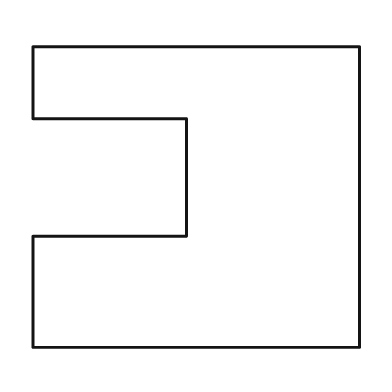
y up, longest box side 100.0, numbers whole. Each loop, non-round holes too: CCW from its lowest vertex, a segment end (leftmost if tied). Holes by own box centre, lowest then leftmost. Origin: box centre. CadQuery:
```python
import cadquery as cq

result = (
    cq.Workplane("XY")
    .moveTo(-50.0, -46.0)
    .lineTo(50.0, -46.0)
    .lineTo(50.0, 46.0)
    .lineTo(-50.0, 46.0)
    .lineTo(-50.0, 24.0)
    .lineTo(-3.0, 24.0)
    .lineTo(-3.0, -12.0)
    .lineTo(-50.0, -12.0)
    .close()
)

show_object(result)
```